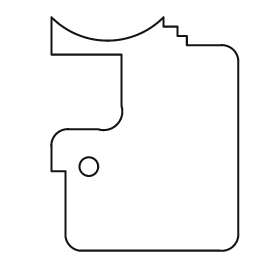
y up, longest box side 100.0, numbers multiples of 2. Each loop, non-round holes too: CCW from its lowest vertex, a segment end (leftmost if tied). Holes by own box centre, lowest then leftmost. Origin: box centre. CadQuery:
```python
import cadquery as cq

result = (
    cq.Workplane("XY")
    .moveTo(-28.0, -50.0)
    .lineTo(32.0, -50.0)
    .threePointArc((38.0, -48.0), (40.0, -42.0))
    .lineTo(40.0, 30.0)
    .threePointArc((38.0, 36.0), (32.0, 38.0))
    .lineTo(18.0, 38.0)
    .lineTo(18.0, 42.0)
    .lineTo(14.0, 42.0)
    .lineTo(14.0, 46.0)
    .lineTo(8.0, 46.0)
    .lineTo(8.0, 50.0)
    .threePointArc((-16.0, 40.0), (-40.0, 50.0))
    .lineTo(-40.0, 34.0)
    .lineTo(-10.0, 34.0)
    .lineTo(-10.0, 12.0)
    .threePointArc((-12.0, 4.0), (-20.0, 2.0))
    .lineTo(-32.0, 2.0)
    .threePointArc((-38.0, 0.0), (-40.0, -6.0))
    .lineTo(-40.0, -16.0)
    .lineTo(-34.0, -16.0)
    .lineTo(-34.0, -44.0)
    .threePointArc((-32.0, -48.0), (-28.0, -50.0))
    .close()
    .moveTo(-24.0, -14.0)
    .circle(4.0)
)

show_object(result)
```